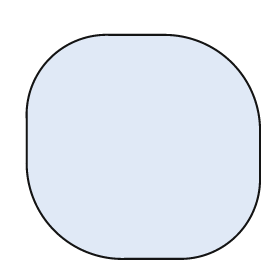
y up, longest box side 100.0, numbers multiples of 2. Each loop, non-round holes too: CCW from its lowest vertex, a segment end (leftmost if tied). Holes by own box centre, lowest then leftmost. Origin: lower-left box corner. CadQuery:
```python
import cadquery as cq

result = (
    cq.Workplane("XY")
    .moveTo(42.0, 0.0)
    .lineTo(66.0, 0.0)
    .threePointArc((90.0, 10.0), (100.0, 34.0))
    .lineTo(100.0, 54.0)
    .threePointArc((88.0, 84.0), (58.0, 96.0))
    .lineTo(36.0, 96.0)
    .threePointArc((10.0, 86.0), (0.0, 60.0))
    .lineTo(0.0, 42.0)
    .threePointArc((12.0, 12.0), (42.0, 0.0))
    .close()
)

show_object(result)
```